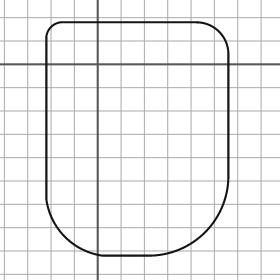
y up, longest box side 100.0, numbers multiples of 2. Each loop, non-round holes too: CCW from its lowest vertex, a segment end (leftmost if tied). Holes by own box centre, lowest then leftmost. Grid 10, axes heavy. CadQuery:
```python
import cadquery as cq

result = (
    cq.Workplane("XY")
    .moveTo(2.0, -82.0)
    .lineTo(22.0, -82.0)
    .threePointArc((46.0, -72.0), (56.0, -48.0))
    .lineTo(56.0, 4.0)
    .threePointArc((52.0, 14.0), (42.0, 18.0))
    .lineTo(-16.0, 18.0)
    .threePointArc((-20.0, 16.0), (-22.0, 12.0))
    .lineTo(-22.0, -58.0)
    .threePointArc((-14.0, -74.0), (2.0, -82.0))
    .close()
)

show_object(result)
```